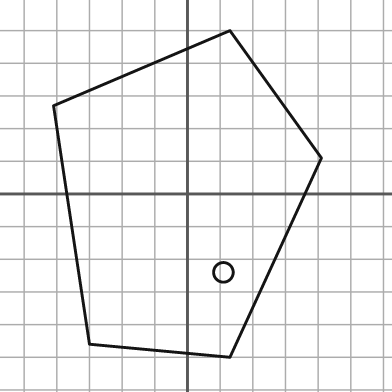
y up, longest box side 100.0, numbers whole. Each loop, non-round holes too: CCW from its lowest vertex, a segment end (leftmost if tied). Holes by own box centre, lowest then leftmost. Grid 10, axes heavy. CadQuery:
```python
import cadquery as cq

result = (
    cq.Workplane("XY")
    .moveTo(13.0, -50.0)
    .lineTo(41.0, 11.0)
    .lineTo(13.0, 50.0)
    .lineTo(-41.0, 27.0)
    .lineTo(-30.0, -46.0)
    .close()
    .moveTo(11.0, -24.0)
    .circle(3.0)
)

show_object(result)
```